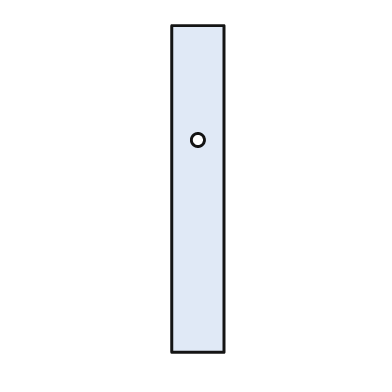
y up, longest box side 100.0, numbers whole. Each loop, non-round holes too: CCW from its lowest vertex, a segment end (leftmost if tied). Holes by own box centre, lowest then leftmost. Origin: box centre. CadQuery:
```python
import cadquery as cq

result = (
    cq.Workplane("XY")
    .moveTo(-8.0, -50.0)
    .lineTo(8.0, -50.0)
    .lineTo(8.0, 50.0)
    .lineTo(-8.0, 50.0)
    .close()
    .moveTo(0.0, 15.0)
    .circle(2.0)
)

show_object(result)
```